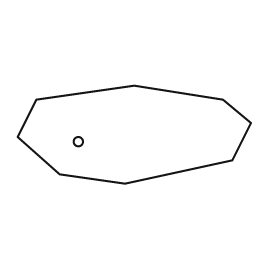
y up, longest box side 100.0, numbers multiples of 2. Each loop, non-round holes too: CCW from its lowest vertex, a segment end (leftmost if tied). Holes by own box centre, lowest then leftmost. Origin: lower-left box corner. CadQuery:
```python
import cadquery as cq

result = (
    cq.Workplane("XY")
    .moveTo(46.0, 0.0)
    .lineTo(92.0, 10.0)
    .lineTo(100.0, 26.0)
    .lineTo(88.0, 36.0)
    .lineTo(50.0, 42.0)
    .lineTo(8.0, 36.0)
    .lineTo(0.0, 20.0)
    .lineTo(18.0, 4.0)
    .close()
    .moveTo(26.0, 18.0)
    .circle(2.0)
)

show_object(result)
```